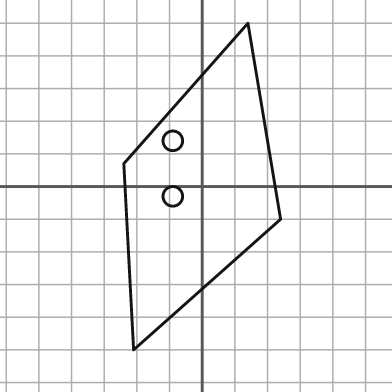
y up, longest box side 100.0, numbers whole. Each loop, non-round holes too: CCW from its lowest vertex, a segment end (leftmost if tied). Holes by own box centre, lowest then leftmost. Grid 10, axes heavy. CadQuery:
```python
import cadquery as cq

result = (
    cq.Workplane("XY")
    .moveTo(-21.0, -50.0)
    .lineTo(24.0, -10.0)
    .lineTo(14.0, 50.0)
    .lineTo(-24.0, 7.0)
    .close()
    .moveTo(-9.0, -3.0)
    .circle(3.0)
    .moveTo(-9.0, 14.0)
    .circle(3.0)
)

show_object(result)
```